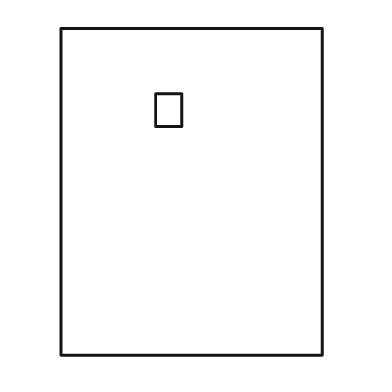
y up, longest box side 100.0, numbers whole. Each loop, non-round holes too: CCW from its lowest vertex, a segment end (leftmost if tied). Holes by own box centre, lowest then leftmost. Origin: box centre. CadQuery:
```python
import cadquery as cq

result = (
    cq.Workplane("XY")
    .moveTo(-40.0, -50.0)
    .lineTo(40.0, -50.0)
    .lineTo(40.0, 50.0)
    .lineTo(-40.0, 50.0)
    .close()
    .moveTo(-11.0, 20.0)
    .lineTo(-3.0, 20.0)
    .lineTo(-3.0, 30.0)
    .lineTo(-11.0, 30.0)
    .close()
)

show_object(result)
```